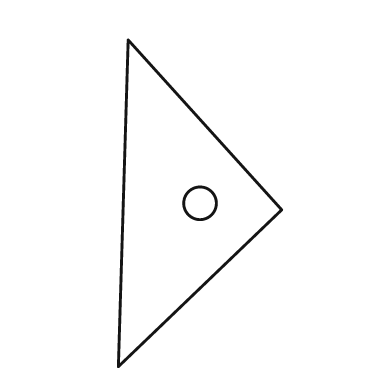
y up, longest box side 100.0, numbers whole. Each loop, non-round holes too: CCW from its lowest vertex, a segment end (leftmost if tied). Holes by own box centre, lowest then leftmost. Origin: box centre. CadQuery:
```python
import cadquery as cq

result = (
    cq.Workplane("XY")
    .moveTo(-25.0, -50.0)
    .lineTo(25.0, -2.0)
    .lineTo(-22.0, 50.0)
    .close()
    .moveTo(0.0, 0.0)
    .circle(5.0)
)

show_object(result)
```